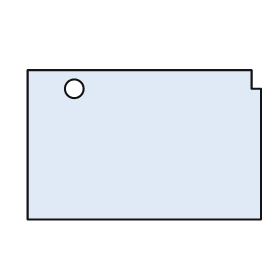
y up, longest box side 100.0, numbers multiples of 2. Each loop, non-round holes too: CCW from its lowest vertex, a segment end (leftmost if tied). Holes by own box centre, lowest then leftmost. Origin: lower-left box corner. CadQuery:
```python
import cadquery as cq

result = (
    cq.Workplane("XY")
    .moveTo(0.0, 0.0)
    .lineTo(100.0, 0.0)
    .lineTo(100.0, 56.0)
    .lineTo(96.0, 56.0)
    .lineTo(96.0, 64.0)
    .lineTo(0.0, 64.0)
    .close()
    .moveTo(20.0, 56.0)
    .circle(4.0)
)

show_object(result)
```